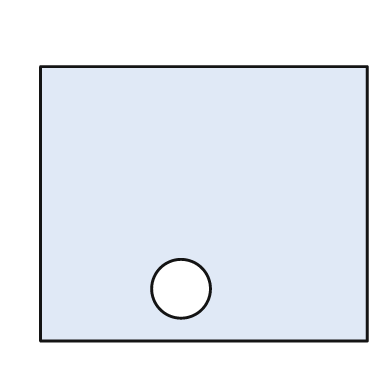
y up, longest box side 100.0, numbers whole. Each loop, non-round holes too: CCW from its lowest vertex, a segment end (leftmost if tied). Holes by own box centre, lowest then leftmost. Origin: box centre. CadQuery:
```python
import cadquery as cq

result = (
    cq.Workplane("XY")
    .moveTo(-50.0, -42.0)
    .lineTo(50.0, -42.0)
    .lineTo(50.0, 42.0)
    .lineTo(-50.0, 42.0)
    .close()
    .moveTo(-7.0, -26.0)
    .circle(9.0)
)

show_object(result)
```